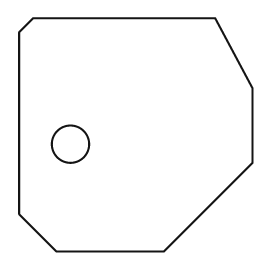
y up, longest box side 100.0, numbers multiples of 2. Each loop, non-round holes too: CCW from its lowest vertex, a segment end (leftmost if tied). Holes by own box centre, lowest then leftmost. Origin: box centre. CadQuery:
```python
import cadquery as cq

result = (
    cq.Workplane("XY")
    .moveTo(-34.0, -50.0)
    .lineTo(12.0, -50.0)
    .lineTo(50.0, -12.0)
    .lineTo(50.0, 20.0)
    .lineTo(34.0, 50.0)
    .lineTo(-44.0, 50.0)
    .lineTo(-50.0, 44.0)
    .lineTo(-50.0, -34.0)
    .close()
    .moveTo(-28.0, -4.0)
    .circle(8.0)
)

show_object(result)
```